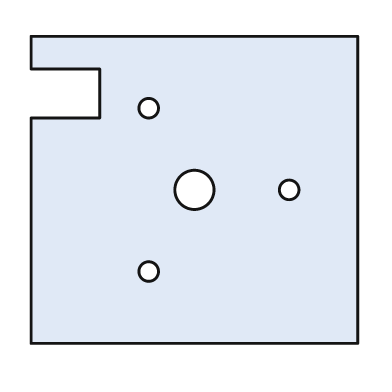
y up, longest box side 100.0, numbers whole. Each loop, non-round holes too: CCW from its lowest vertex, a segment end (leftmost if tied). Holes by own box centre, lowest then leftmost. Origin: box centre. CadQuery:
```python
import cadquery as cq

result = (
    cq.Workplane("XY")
    .moveTo(-50.0, -47.0)
    .lineTo(50.0, -47.0)
    .lineTo(50.0, 47.0)
    .lineTo(-50.0, 47.0)
    .lineTo(-50.0, 37.0)
    .lineTo(-29.0, 37.0)
    .lineTo(-29.0, 22.0)
    .lineTo(-50.0, 22.0)
    .close()
    .moveTo(-14.0, -25.0)
    .circle(3.0)
    .moveTo(0.0, 0.0)
    .circle(6.0)
    .moveTo(29.0, 0.0)
    .circle(3.0)
    .moveTo(-14.0, 25.0)
    .circle(3.0)
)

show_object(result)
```